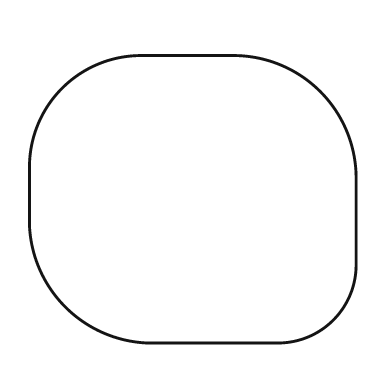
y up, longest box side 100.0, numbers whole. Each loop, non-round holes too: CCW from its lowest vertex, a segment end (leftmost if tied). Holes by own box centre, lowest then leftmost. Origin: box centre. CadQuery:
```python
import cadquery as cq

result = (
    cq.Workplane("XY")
    .moveTo(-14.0, -44.0)
    .lineTo(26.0, -44.0)
    .threePointArc((43.0, -37.0), (50.0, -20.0))
    .lineTo(50.0, 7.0)
    .threePointArc((39.0, 33.0), (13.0, 44.0))
    .lineTo(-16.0, 44.0)
    .threePointArc((-40.0, 34.0), (-50.0, 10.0))
    .lineTo(-50.0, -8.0)
    .threePointArc((-39.0, -33.0), (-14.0, -44.0))
    .close()
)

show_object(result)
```